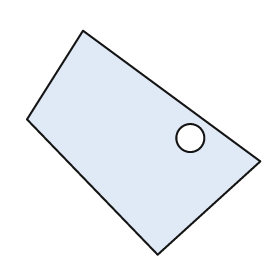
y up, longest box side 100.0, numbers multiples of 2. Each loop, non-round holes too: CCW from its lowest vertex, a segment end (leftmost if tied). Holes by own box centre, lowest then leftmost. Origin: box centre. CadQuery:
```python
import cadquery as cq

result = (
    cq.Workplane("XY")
    .moveTo(6.0, -48.0)
    .lineTo(50.0, -8.0)
    .lineTo(-26.0, 48.0)
    .lineTo(-50.0, 10.0)
    .close()
    .moveTo(20.0, 2.0)
    .circle(6.0)
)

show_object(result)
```